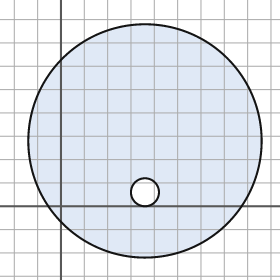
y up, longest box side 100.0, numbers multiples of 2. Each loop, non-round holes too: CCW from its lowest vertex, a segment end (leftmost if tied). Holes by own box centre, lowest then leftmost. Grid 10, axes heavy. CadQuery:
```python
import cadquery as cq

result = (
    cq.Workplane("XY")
    .moveTo(36.0, 28.0)
    .circle(50.0)
    .moveTo(36.0, 6.0)
    .circle(6.0)
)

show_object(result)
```